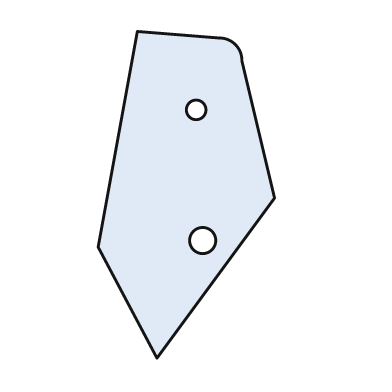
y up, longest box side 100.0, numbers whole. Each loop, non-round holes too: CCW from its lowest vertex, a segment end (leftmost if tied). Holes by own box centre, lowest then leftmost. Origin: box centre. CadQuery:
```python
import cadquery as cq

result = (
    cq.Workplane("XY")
    .moveTo(-9.0, -50.0)
    .lineTo(27.0, -1.0)
    .lineTo(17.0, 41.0)
    .threePointArc((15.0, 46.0), (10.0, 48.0))
    .lineTo(-15.0, 50.0)
    .lineTo(-27.0, -16.0)
    .close()
    .moveTo(5.0, -14.0)
    .circle(4.0)
    .moveTo(3.0, 26.0)
    .circle(3.0)
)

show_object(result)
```